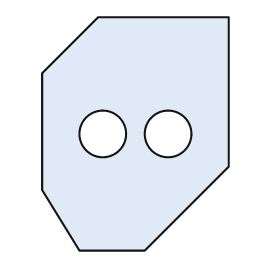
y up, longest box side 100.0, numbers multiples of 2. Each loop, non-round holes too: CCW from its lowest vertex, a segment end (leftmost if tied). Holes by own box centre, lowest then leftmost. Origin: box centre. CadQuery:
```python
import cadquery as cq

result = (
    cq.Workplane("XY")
    .moveTo(-24.0, -50.0)
    .lineTo(4.0, -50.0)
    .lineTo(40.0, -14.0)
    .lineTo(40.0, 50.0)
    .lineTo(-16.0, 50.0)
    .lineTo(-40.0, 26.0)
    .lineTo(-40.0, -24.0)
    .close()
    .moveTo(-14.0, 0.0)
    .circle(10.0)
    .moveTo(14.0, 0.0)
    .circle(10.0)
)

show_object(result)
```